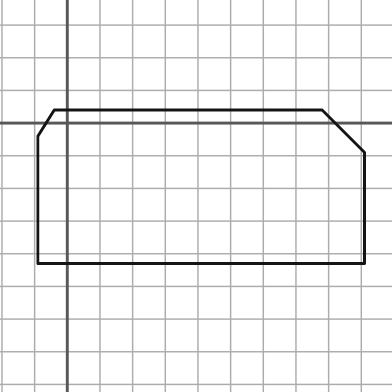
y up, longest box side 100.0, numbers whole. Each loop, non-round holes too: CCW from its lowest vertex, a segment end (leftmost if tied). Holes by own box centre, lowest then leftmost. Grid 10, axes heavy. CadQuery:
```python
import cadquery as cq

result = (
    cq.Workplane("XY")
    .moveTo(-9.0, -43.0)
    .lineTo(91.0, -43.0)
    .lineTo(91.0, -9.0)
    .lineTo(78.0, 4.0)
    .lineTo(-4.0, 4.0)
    .lineTo(-9.0, -4.0)
    .close()
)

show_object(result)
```